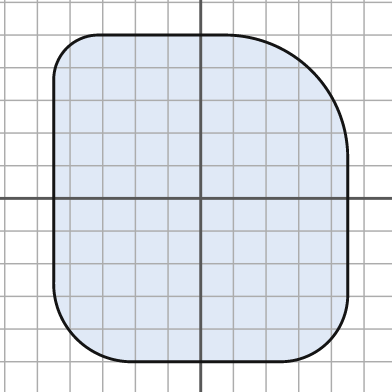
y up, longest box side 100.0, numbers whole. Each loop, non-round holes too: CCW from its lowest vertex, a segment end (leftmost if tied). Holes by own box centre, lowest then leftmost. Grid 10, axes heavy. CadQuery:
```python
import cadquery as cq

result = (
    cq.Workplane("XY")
    .moveTo(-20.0, -50.0)
    .lineTo(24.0, -50.0)
    .threePointArc((39.0, -44.0), (45.0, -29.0))
    .lineTo(45.0, 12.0)
    .threePointArc((34.0, 39.0), (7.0, 50.0))
    .lineTo(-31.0, 50.0)
    .threePointArc((-41.0, 46.0), (-45.0, 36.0))
    .lineTo(-45.0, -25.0)
    .threePointArc((-38.0, -43.0), (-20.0, -50.0))
    .close()
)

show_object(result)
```